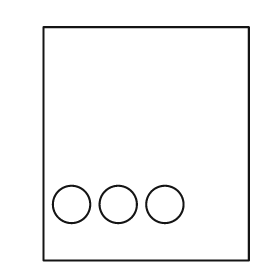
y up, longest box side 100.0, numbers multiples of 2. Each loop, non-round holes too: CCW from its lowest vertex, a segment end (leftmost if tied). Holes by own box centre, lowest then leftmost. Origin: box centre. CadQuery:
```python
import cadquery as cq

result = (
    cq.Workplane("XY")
    .moveTo(-44.0, -50.0)
    .lineTo(44.0, -50.0)
    .lineTo(44.0, 50.0)
    .lineTo(-44.0, 50.0)
    .close()
    .moveTo(-32.0, -26.0)
    .circle(8.0)
    .moveTo(-12.0, -26.0)
    .circle(8.0)
    .moveTo(8.0, -26.0)
    .circle(8.0)
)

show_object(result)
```